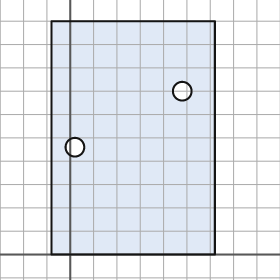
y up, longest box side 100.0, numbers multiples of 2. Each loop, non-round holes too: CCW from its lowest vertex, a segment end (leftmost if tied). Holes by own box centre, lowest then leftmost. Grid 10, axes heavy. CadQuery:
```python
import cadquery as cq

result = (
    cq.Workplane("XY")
    .moveTo(-8.0, 0.0)
    .lineTo(62.0, 0.0)
    .lineTo(62.0, 100.0)
    .lineTo(-8.0, 100.0)
    .close()
    .moveTo(2.0, 46.0)
    .circle(4.0)
    .moveTo(48.0, 70.0)
    .circle(4.0)
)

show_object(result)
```